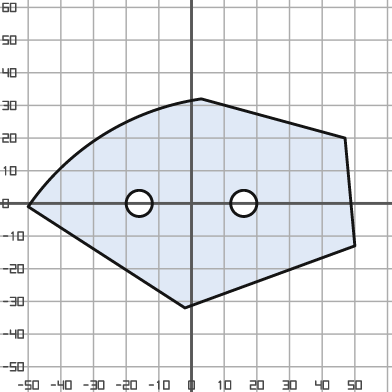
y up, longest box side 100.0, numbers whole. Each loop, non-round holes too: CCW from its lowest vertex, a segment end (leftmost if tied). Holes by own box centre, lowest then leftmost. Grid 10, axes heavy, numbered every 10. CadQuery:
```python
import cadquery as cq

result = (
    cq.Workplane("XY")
    .moveTo(-2.0, -32.0)
    .lineTo(50.0, -13.0)
    .lineTo(47.0, 20.0)
    .lineTo(3.0, 32.0)
    .threePointArc((-27.0, 21.0), (-50.0, -1.0))
    .close()
    .moveTo(-16.0, 0.0)
    .circle(4.0)
    .moveTo(16.0, 0.0)
    .circle(4.0)
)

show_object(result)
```